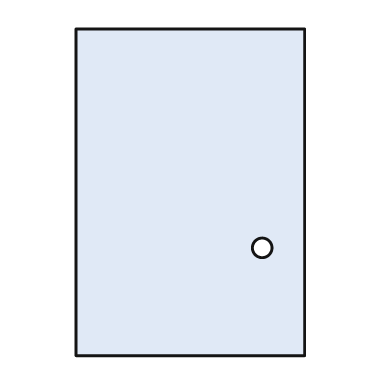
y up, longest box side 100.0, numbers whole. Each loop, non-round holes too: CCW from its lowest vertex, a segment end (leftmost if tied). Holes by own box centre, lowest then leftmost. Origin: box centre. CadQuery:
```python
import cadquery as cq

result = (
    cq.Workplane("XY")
    .moveTo(-35.0, -50.0)
    .lineTo(35.0, -50.0)
    .lineTo(35.0, 50.0)
    .lineTo(-35.0, 50.0)
    .close()
    .moveTo(22.0, -17.0)
    .circle(3.0)
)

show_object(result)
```